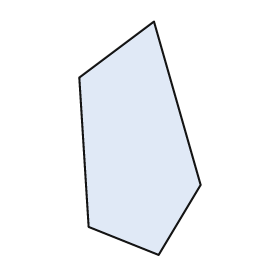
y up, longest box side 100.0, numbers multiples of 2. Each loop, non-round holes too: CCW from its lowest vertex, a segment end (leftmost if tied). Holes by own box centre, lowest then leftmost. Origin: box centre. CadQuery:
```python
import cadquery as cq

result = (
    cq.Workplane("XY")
    .moveTo(8.0, -50.0)
    .lineTo(26.0, -20.0)
    .lineTo(6.0, 50.0)
    .lineTo(-26.0, 26.0)
    .lineTo(-22.0, -38.0)
    .close()
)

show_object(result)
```